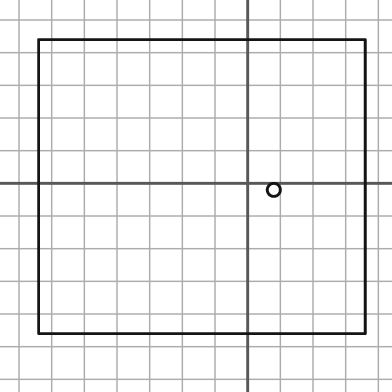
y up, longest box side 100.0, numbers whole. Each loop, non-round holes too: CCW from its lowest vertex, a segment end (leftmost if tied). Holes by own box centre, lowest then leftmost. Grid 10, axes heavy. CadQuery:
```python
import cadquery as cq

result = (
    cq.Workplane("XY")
    .moveTo(-64.0, -46.0)
    .lineTo(36.0, -46.0)
    .lineTo(36.0, 44.0)
    .lineTo(-64.0, 44.0)
    .close()
    .moveTo(8.0, -2.0)
    .circle(2.0)
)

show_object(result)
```